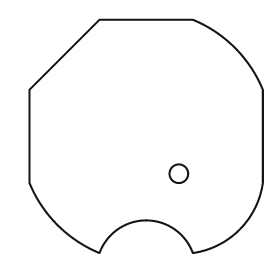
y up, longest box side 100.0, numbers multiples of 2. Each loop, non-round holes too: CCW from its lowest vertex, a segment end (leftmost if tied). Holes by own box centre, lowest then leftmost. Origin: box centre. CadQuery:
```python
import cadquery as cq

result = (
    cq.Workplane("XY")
    .moveTo(-20.0, -50.0)
    .threePointArc((0.0, -36.0), (20.0, -50.0))
    .threePointArc((40.0, -40.0), (50.0, -20.0))
    .lineTo(50.0, 20.0)
    .threePointArc((38.0, 38.0), (20.0, 50.0))
    .lineTo(-20.0, 50.0)
    .lineTo(-50.0, 20.0)
    .lineTo(-50.0, -20.0)
    .threePointArc((-38.0, -38.0), (-20.0, -50.0))
    .close()
    .moveTo(14.0, -16.0)
    .circle(4.0)
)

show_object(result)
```